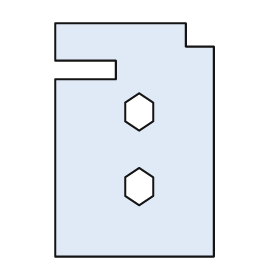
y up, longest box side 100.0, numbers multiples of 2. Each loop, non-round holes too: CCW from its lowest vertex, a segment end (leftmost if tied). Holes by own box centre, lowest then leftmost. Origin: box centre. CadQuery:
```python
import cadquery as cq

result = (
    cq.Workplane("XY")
    .moveTo(-34.0, -50.0)
    .lineTo(34.0, -50.0)
    .lineTo(34.0, 40.0)
    .lineTo(22.0, 40.0)
    .lineTo(22.0, 50.0)
    .lineTo(-34.0, 50.0)
    .lineTo(-34.0, 34.0)
    .lineTo(-8.0, 34.0)
    .lineTo(-8.0, 26.0)
    .lineTo(-34.0, 26.0)
    .close()
    .moveTo(2.0, -28.0)
    .lineTo(8.0, -24.0)
    .lineTo(8.0, -16.0)
    .lineTo(2.0, -12.0)
    .lineTo(-4.0, -16.0)
    .lineTo(-4.0, -24.0)
    .close()
    .moveTo(2.0, 4.0)
    .lineTo(8.0, 8.0)
    .lineTo(8.0, 16.0)
    .lineTo(2.0, 20.0)
    .lineTo(-4.0, 16.0)
    .lineTo(-4.0, 8.0)
    .close()
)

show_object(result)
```